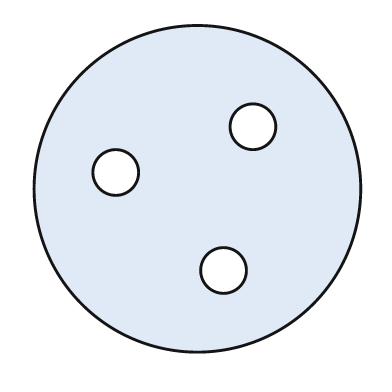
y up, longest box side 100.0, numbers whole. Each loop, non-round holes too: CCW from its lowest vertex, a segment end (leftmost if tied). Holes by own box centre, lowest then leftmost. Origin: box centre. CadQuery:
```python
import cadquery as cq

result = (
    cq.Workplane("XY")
    .moveTo(0.0, 0.0)
    .circle(50.0)
    .moveTo(8.0, -25.0)
    .circle(7.0)
    .moveTo(-25.0, 5.0)
    .circle(7.0)
    .moveTo(17.0, 19.0)
    .circle(7.0)
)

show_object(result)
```